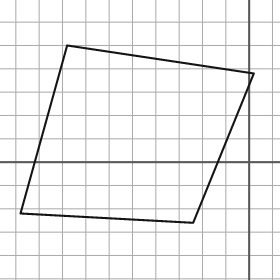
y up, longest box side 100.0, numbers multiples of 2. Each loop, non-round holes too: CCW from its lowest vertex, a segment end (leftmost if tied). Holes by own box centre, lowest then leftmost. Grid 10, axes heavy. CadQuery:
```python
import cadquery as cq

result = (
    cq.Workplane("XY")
    .moveTo(-24.0, -26.0)
    .lineTo(2.0, 38.0)
    .lineTo(-78.0, 50.0)
    .lineTo(-98.0, -22.0)
    .close()
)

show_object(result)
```